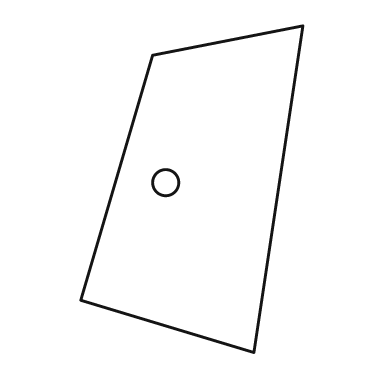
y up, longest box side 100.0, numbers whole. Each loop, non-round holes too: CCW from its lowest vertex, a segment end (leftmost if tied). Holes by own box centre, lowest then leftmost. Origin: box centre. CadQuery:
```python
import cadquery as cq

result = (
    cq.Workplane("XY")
    .moveTo(19.0, -50.0)
    .lineTo(34.0, 50.0)
    .lineTo(-12.0, 41.0)
    .lineTo(-34.0, -34.0)
    .close()
    .moveTo(-8.0, 2.0)
    .circle(4.0)
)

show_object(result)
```